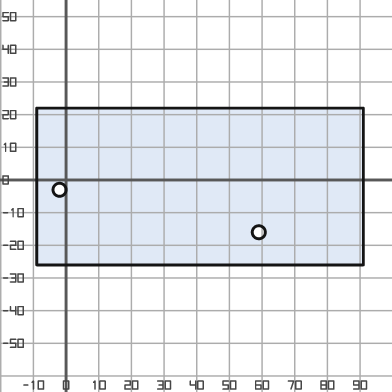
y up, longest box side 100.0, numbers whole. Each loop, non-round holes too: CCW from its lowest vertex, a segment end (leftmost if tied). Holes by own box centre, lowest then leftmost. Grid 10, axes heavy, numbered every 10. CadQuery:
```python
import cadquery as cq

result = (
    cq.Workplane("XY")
    .moveTo(-9.0, -26.0)
    .lineTo(91.0, -26.0)
    .lineTo(91.0, 22.0)
    .lineTo(-9.0, 22.0)
    .close()
    .moveTo(59.0, -16.0)
    .circle(2.0)
    .moveTo(-2.0, -3.0)
    .circle(2.0)
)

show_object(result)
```